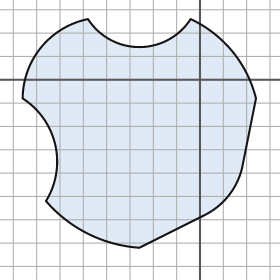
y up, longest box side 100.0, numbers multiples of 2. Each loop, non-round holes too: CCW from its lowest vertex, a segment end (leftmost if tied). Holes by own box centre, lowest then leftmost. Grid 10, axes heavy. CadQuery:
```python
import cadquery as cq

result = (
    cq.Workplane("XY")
    .moveTo(-26.0, -72.0)
    .lineTo(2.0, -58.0)
    .threePointArc((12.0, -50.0), (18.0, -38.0))
    .lineTo(24.0, -8.0)
    .threePointArc((14.0, 12.0), (-4.0, 26.0))
    .threePointArc((-26.0, 14.0), (-48.0, 26.0))
    .threePointArc((-68.0, 14.0), (-76.0, -8.0))
    .threePointArc((-62.0, -28.0), (-66.0, -52.0))
    .threePointArc((-48.0, -66.0), (-26.0, -72.0))
    .close()
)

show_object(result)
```